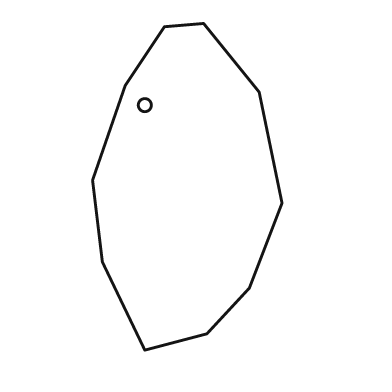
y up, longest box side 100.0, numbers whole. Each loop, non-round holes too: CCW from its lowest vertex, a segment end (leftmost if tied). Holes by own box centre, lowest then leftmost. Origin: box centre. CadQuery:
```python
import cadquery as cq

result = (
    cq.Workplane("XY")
    .moveTo(-13.0, -50.0)
    .lineTo(6.0, -45.0)
    .lineTo(19.0, -31.0)
    .lineTo(29.0, -5.0)
    .lineTo(22.0, 29.0)
    .lineTo(5.0, 50.0)
    .lineTo(-7.0, 49.0)
    .lineTo(-19.0, 31.0)
    .lineTo(-29.0, 2.0)
    .lineTo(-26.0, -23.0)
    .close()
    .moveTo(-13.0, 25.0)
    .circle(2.0)
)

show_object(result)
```